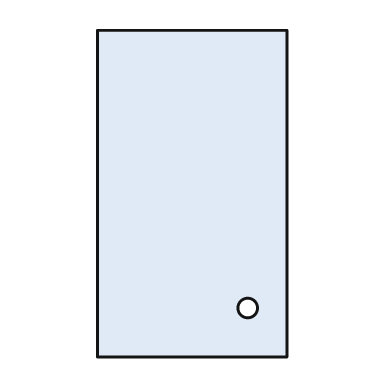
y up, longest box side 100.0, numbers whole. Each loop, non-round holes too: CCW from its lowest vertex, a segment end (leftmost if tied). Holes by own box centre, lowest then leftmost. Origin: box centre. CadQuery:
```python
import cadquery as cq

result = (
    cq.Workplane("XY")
    .moveTo(-29.0, -50.0)
    .lineTo(29.0, -50.0)
    .lineTo(29.0, 50.0)
    .lineTo(-29.0, 50.0)
    .close()
    .moveTo(17.0, -35.0)
    .circle(3.0)
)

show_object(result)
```